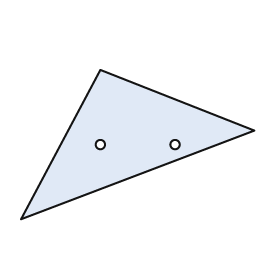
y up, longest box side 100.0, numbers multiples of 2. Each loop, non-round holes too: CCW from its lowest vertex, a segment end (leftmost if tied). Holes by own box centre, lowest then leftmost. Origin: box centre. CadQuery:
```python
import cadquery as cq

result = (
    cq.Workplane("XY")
    .moveTo(-50.0, -32.0)
    .lineTo(50.0, 6.0)
    .lineTo(-16.0, 32.0)
    .close()
    .moveTo(-16.0, 0.0)
    .circle(2.0)
    .moveTo(16.0, 0.0)
    .circle(2.0)
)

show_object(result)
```